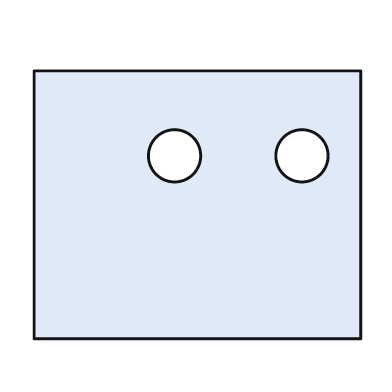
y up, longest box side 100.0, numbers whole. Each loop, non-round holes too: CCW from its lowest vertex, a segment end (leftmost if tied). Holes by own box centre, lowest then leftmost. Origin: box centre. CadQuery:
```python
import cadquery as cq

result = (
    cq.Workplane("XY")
    .moveTo(-50.0, -41.0)
    .lineTo(50.0, -41.0)
    .lineTo(50.0, 41.0)
    .lineTo(-50.0, 41.0)
    .close()
    .moveTo(-7.0, 15.0)
    .circle(8.0)
    .moveTo(32.0, 15.0)
    .circle(8.0)
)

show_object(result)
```